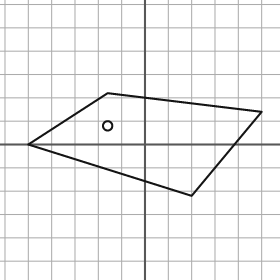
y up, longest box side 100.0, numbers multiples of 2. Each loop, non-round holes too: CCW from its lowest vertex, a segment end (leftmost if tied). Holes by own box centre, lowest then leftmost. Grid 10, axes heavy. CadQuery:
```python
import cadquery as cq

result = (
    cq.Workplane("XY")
    .moveTo(20.0, -22.0)
    .lineTo(50.0, 14.0)
    .lineTo(-16.0, 22.0)
    .lineTo(-50.0, 0.0)
    .close()
    .moveTo(-16.0, 8.0)
    .circle(2.0)
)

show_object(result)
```